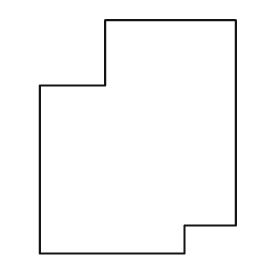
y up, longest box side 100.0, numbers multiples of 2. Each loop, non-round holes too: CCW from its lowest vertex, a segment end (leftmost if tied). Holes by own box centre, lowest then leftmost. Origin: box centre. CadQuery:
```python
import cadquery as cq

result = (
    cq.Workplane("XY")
    .moveTo(-42.0, -50.0)
    .lineTo(20.0, -50.0)
    .lineTo(20.0, -38.0)
    .lineTo(42.0, -38.0)
    .lineTo(42.0, 50.0)
    .lineTo(-14.0, 50.0)
    .lineTo(-14.0, 22.0)
    .lineTo(-42.0, 22.0)
    .close()
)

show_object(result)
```